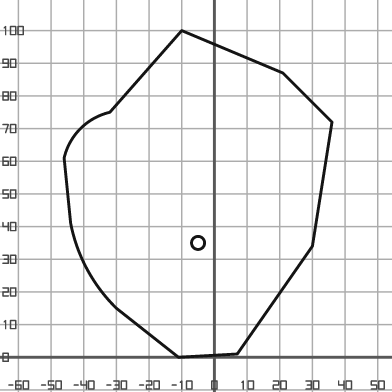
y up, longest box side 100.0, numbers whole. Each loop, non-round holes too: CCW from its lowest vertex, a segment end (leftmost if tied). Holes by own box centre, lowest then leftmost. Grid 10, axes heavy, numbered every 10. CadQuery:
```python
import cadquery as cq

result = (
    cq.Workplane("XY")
    .moveTo(-11.0, 0.0)
    .lineTo(7.0, 1.0)
    .lineTo(30.0, 34.0)
    .lineTo(36.0, 72.0)
    .lineTo(21.0, 87.0)
    .lineTo(-10.0, 100.0)
    .lineTo(-32.0, 75.0)
    .threePointArc((-41.0, 70.0), (-46.0, 61.0))
    .lineTo(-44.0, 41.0)
    .threePointArc((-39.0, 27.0), (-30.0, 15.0))
    .close()
    .moveTo(-5.0, 35.0)
    .circle(2.0)
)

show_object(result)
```